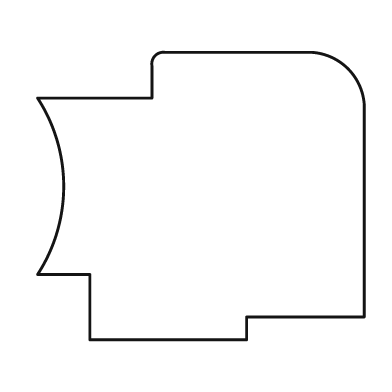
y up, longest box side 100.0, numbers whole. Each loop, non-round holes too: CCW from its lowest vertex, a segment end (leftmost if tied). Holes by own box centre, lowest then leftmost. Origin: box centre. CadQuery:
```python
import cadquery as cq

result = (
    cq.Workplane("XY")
    .moveTo(-34.0, -44.0)
    .lineTo(14.0, -44.0)
    .lineTo(14.0, -37.0)
    .lineTo(50.0, -37.0)
    .lineTo(50.0, 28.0)
    .threePointArc((45.0, 39.0), (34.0, 44.0))
    .lineTo(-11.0, 44.0)
    .threePointArc((-14.0, 43.0), (-15.0, 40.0))
    .lineTo(-15.0, 30.0)
    .lineTo(-50.0, 30.0)
    .threePointArc((-42.0, 3.0), (-50.0, -24.0))
    .lineTo(-34.0, -24.0)
    .close()
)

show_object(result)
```